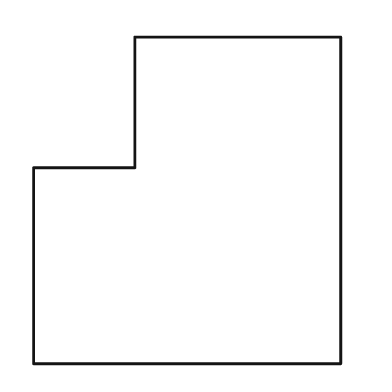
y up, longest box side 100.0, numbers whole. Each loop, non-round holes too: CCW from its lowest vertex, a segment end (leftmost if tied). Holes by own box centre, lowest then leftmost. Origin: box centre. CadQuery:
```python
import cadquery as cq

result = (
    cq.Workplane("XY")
    .moveTo(-47.0, -50.0)
    .lineTo(47.0, -50.0)
    .lineTo(47.0, 50.0)
    .lineTo(-16.0, 50.0)
    .lineTo(-16.0, 10.0)
    .lineTo(-47.0, 10.0)
    .close()
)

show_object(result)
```